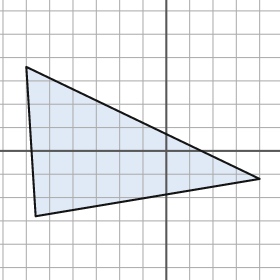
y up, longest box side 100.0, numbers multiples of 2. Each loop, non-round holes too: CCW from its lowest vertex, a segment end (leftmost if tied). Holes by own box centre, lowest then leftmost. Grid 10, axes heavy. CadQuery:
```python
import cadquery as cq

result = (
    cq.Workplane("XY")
    .moveTo(-56.0, -28.0)
    .lineTo(40.0, -12.0)
    .lineTo(-60.0, 36.0)
    .close()
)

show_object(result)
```